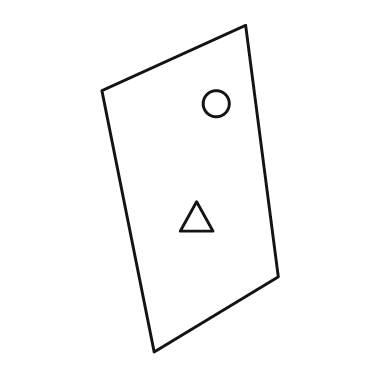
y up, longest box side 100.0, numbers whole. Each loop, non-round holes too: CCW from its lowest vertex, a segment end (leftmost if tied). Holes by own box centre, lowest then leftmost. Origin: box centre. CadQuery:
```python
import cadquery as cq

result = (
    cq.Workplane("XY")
    .moveTo(-11.0, -50.0)
    .lineTo(27.0, -27.0)
    .lineTo(17.0, 50.0)
    .lineTo(-27.0, 30.0)
    .close()
    .moveTo(-3.0, -13.0)
    .lineTo(7.0, -13.0)
    .lineTo(2.0, -4.0)
    .close()
    .moveTo(8.0, 26.0)
    .circle(4.0)
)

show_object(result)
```